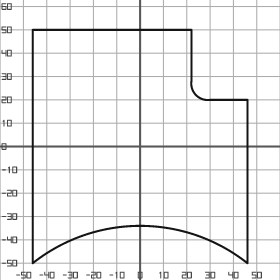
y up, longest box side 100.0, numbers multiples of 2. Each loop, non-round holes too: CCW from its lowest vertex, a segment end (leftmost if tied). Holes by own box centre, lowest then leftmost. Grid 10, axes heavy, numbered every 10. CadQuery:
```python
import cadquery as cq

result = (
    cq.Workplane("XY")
    .moveTo(-46.0, -50.0)
    .threePointArc((0.0, -34.0), (46.0, -50.0))
    .lineTo(46.0, 20.0)
    .lineTo(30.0, 20.0)
    .threePointArc((24.0, 22.0), (22.0, 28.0))
    .lineTo(22.0, 50.0)
    .lineTo(-46.0, 50.0)
    .close()
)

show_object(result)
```